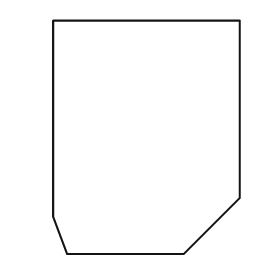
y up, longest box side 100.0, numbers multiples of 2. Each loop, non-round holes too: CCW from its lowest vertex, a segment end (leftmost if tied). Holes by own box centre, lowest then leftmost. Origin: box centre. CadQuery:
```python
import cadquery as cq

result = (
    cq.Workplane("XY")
    .moveTo(-34.0, -50.0)
    .lineTo(16.0, -50.0)
    .lineTo(40.0, -26.0)
    .lineTo(40.0, 50.0)
    .lineTo(-40.0, 50.0)
    .lineTo(-40.0, -34.0)
    .close()
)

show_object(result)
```